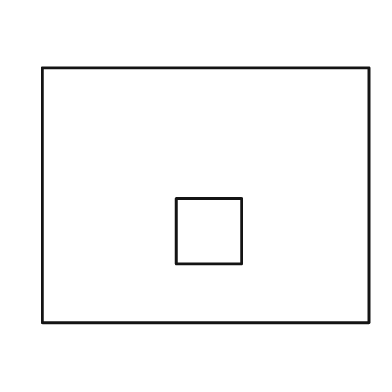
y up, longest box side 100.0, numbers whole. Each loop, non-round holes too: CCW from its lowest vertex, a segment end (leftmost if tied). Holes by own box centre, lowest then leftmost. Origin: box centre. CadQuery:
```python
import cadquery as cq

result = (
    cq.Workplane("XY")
    .moveTo(-50.0, -39.0)
    .lineTo(50.0, -39.0)
    .lineTo(50.0, 39.0)
    .lineTo(-50.0, 39.0)
    .close()
    .moveTo(-9.0, -21.0)
    .lineTo(11.0, -21.0)
    .lineTo(11.0, -1.0)
    .lineTo(-9.0, -1.0)
    .close()
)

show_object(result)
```